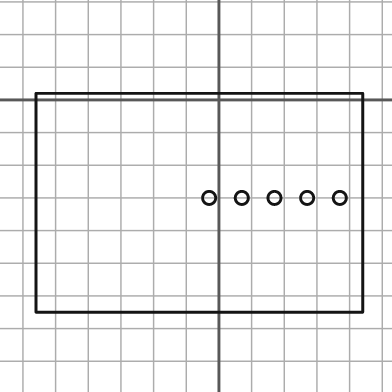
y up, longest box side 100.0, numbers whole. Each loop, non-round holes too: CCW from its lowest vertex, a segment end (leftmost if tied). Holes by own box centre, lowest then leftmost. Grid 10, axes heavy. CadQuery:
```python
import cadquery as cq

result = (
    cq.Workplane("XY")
    .moveTo(-56.0, -65.0)
    .lineTo(44.0, -65.0)
    .lineTo(44.0, 2.0)
    .lineTo(-56.0, 2.0)
    .close()
    .moveTo(-3.0, -30.0)
    .circle(2.0)
    .moveTo(7.0, -30.0)
    .circle(2.0)
    .moveTo(17.0, -30.0)
    .circle(2.0)
    .moveTo(27.0, -30.0)
    .circle(2.0)
    .moveTo(37.0, -30.0)
    .circle(2.0)
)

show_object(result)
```